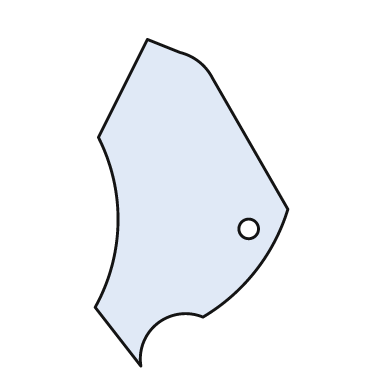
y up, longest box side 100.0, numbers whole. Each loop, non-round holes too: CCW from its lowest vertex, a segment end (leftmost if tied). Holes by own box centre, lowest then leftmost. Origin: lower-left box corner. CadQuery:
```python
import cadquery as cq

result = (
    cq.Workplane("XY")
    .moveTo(14.0, 0.0)
    .threePointArc((19.0, 13.0), (33.0, 15.0))
    .threePointArc((49.0, 29.0), (59.0, 48.0))
    .lineTo(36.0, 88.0)
    .threePointArc((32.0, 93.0), (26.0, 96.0))
    .lineTo(16.0, 100.0)
    .lineTo(1.0, 70.0)
    .threePointArc((7.0, 44.0), (0.0, 18.0))
    .close()
    .moveTo(47.0, 42.0)
    .circle(3.0)
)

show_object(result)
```